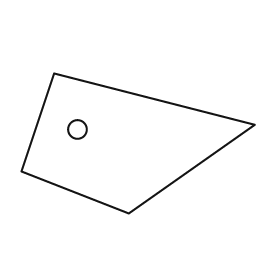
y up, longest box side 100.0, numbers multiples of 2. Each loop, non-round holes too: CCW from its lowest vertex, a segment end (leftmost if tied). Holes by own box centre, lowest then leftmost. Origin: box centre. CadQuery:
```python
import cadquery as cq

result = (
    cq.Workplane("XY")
    .moveTo(-4.0, -30.0)
    .lineTo(50.0, 8.0)
    .lineTo(-36.0, 30.0)
    .lineTo(-50.0, -12.0)
    .close()
    .moveTo(-26.0, 6.0)
    .circle(4.0)
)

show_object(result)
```